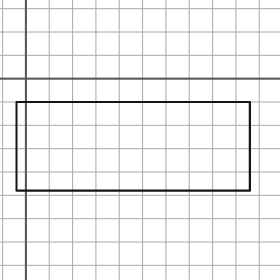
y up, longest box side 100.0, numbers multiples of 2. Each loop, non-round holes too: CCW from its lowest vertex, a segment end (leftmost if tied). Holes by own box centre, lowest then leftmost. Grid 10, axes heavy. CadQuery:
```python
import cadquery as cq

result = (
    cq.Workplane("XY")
    .moveTo(-4.0, -48.0)
    .lineTo(96.0, -48.0)
    .lineTo(96.0, -10.0)
    .lineTo(-4.0, -10.0)
    .close()
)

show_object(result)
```